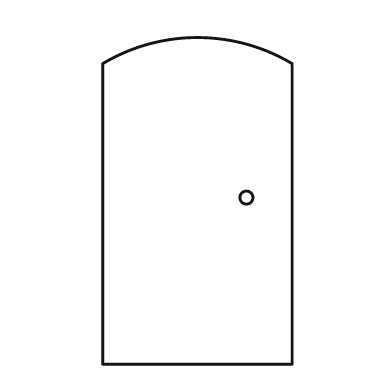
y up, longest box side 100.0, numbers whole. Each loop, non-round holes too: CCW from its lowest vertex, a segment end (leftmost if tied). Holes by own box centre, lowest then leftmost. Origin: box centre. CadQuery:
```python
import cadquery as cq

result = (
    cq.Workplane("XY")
    .moveTo(-29.0, -50.0)
    .lineTo(29.0, -50.0)
    .lineTo(29.0, 42.0)
    .threePointArc((0.0, 50.0), (-29.0, 42.0))
    .close()
    .moveTo(15.0, 1.0)
    .circle(2.0)
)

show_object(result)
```